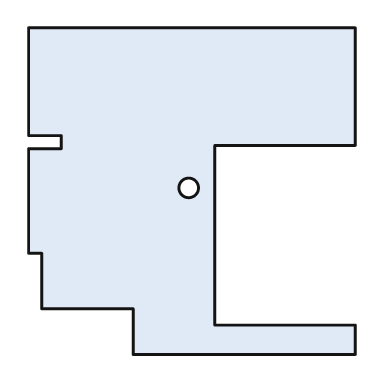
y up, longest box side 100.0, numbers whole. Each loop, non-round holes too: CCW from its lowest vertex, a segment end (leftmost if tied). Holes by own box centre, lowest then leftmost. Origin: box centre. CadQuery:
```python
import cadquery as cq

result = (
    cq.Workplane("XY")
    .moveTo(-18.0, -50.0)
    .lineTo(50.0, -50.0)
    .lineTo(50.0, -41.0)
    .lineTo(7.0, -41.0)
    .lineTo(7.0, 14.0)
    .lineTo(50.0, 14.0)
    .lineTo(50.0, 50.0)
    .lineTo(-50.0, 50.0)
    .lineTo(-50.0, 17.0)
    .lineTo(-40.0, 17.0)
    .lineTo(-40.0, 13.0)
    .lineTo(-50.0, 13.0)
    .lineTo(-50.0, -19.0)
    .lineTo(-46.0, -19.0)
    .lineTo(-46.0, -36.0)
    .lineTo(-18.0, -36.0)
    .close()
    .moveTo(-1.0, 1.0)
    .circle(3.0)
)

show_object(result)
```